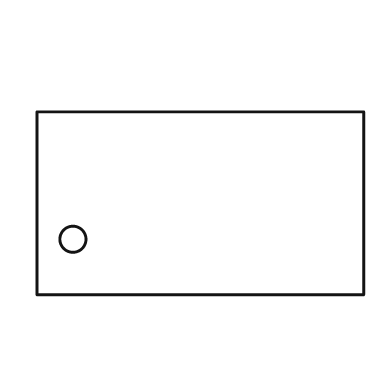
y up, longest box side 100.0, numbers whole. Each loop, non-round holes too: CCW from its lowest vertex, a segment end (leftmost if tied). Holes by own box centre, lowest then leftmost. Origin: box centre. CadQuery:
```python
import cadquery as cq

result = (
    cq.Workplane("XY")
    .moveTo(-50.0, -28.0)
    .lineTo(50.0, -28.0)
    .lineTo(50.0, 28.0)
    .lineTo(-50.0, 28.0)
    .close()
    .moveTo(-39.0, -11.0)
    .circle(4.0)
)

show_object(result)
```